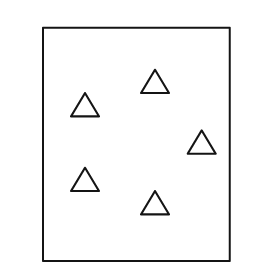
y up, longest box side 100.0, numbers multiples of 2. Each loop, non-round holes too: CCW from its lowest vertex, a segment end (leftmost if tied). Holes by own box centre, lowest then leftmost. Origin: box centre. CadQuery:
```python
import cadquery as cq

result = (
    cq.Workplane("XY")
    .moveTo(-40.0, -50.0)
    .lineTo(40.0, -50.0)
    .lineTo(40.0, 50.0)
    .lineTo(-40.0, 50.0)
    .close()
    .moveTo(2.0, -30.0)
    .lineTo(14.0, -30.0)
    .lineTo(8.0, -20.0)
    .close()
    .moveTo(-28.0, -20.0)
    .lineTo(-16.0, -20.0)
    .lineTo(-22.0, -10.0)
    .close()
    .moveTo(22.0, -4.0)
    .lineTo(34.0, -4.0)
    .lineTo(28.0, 6.0)
    .close()
    .moveTo(-28.0, 12.0)
    .lineTo(-16.0, 12.0)
    .lineTo(-22.0, 22.0)
    .close()
    .moveTo(2.0, 22.0)
    .lineTo(14.0, 22.0)
    .lineTo(8.0, 32.0)
    .close()
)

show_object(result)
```